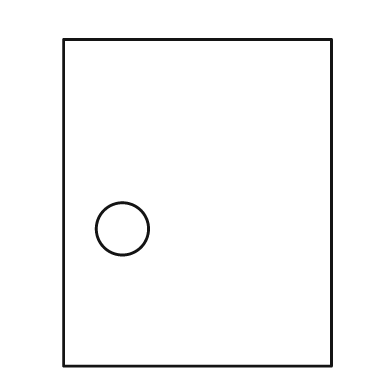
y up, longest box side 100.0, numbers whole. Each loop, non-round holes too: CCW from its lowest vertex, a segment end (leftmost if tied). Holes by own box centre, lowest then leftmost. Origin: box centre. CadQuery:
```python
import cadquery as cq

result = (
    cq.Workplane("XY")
    .moveTo(-41.0, -50.0)
    .lineTo(41.0, -50.0)
    .lineTo(41.0, 50.0)
    .lineTo(-41.0, 50.0)
    .close()
    .moveTo(-23.0, -8.0)
    .circle(8.0)
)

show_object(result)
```